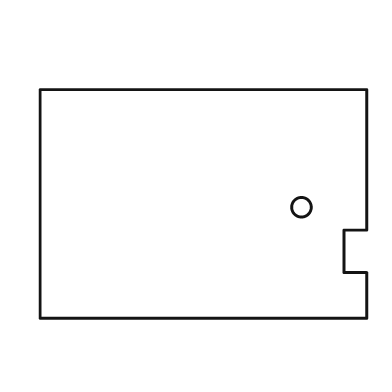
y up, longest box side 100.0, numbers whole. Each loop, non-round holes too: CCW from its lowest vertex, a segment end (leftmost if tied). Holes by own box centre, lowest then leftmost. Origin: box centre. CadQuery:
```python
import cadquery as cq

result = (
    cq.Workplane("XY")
    .moveTo(-50.0, -35.0)
    .lineTo(50.0, -35.0)
    .lineTo(50.0, -21.0)
    .lineTo(43.0, -21.0)
    .lineTo(43.0, -8.0)
    .lineTo(50.0, -8.0)
    .lineTo(50.0, 35.0)
    .lineTo(-50.0, 35.0)
    .close()
    .moveTo(30.0, -1.0)
    .circle(3.0)
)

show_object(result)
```